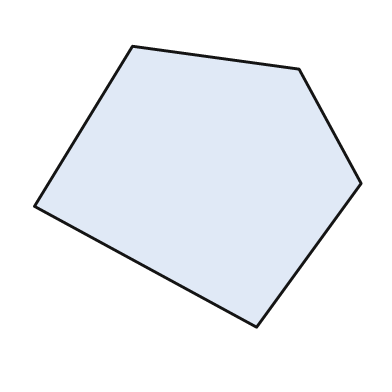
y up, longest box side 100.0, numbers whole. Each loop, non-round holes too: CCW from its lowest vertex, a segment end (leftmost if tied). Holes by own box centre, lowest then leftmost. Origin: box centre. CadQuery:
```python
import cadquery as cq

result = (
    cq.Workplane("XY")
    .moveTo(18.0, -43.0)
    .lineTo(50.0, 1.0)
    .lineTo(31.0, 36.0)
    .lineTo(-20.0, 43.0)
    .lineTo(-50.0, -6.0)
    .close()
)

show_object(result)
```